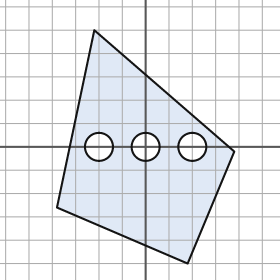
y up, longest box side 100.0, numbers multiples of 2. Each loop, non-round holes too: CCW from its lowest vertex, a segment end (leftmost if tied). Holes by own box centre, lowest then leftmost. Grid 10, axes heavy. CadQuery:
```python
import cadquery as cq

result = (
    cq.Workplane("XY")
    .moveTo(18.0, -50.0)
    .lineTo(38.0, -2.0)
    .lineTo(-22.0, 50.0)
    .lineTo(-38.0, -26.0)
    .close()
    .moveTo(-20.0, 0.0)
    .circle(6.0)
    .moveTo(0.0, 0.0)
    .circle(6.0)
    .moveTo(20.0, 0.0)
    .circle(6.0)
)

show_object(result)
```